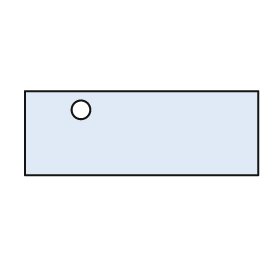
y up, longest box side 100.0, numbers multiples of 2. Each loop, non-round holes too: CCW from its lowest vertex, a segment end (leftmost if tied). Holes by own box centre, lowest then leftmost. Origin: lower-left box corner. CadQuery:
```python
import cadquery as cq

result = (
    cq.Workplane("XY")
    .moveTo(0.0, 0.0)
    .lineTo(100.0, 0.0)
    .lineTo(100.0, 36.0)
    .lineTo(0.0, 36.0)
    .close()
    .moveTo(24.0, 28.0)
    .circle(4.0)
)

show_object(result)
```